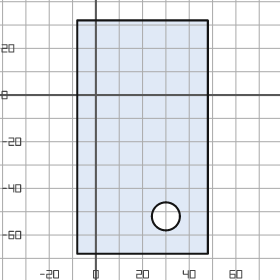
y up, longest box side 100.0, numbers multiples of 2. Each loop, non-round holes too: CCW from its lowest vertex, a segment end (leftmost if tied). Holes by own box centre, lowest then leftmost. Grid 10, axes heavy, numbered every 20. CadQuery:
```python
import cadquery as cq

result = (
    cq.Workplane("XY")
    .moveTo(-8.0, -68.0)
    .lineTo(48.0, -68.0)
    .lineTo(48.0, 32.0)
    .lineTo(-8.0, 32.0)
    .close()
    .moveTo(30.0, -52.0)
    .circle(6.0)
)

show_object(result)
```